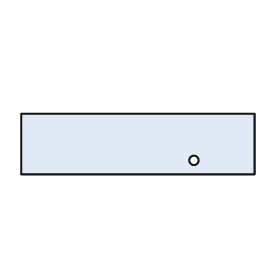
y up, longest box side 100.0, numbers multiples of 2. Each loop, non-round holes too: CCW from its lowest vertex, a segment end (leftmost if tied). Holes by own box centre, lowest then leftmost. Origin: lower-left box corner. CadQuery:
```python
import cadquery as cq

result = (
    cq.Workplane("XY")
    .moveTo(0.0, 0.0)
    .lineTo(100.0, 0.0)
    .lineTo(100.0, 26.0)
    .lineTo(0.0, 26.0)
    .close()
    .moveTo(74.0, 6.0)
    .circle(2.0)
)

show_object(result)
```